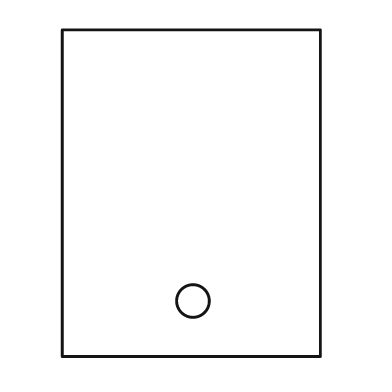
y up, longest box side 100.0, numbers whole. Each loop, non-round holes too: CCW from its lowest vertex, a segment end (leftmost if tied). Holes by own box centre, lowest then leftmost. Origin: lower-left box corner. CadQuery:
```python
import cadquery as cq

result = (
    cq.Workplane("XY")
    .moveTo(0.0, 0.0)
    .lineTo(79.0, 0.0)
    .lineTo(79.0, 100.0)
    .lineTo(0.0, 100.0)
    .close()
    .moveTo(40.0, 17.0)
    .circle(5.0)
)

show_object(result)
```